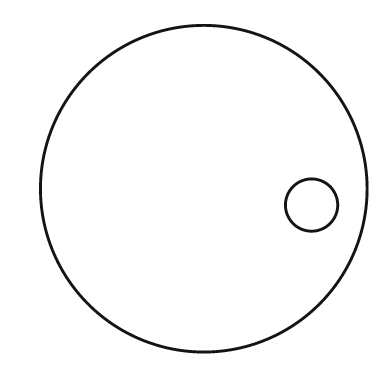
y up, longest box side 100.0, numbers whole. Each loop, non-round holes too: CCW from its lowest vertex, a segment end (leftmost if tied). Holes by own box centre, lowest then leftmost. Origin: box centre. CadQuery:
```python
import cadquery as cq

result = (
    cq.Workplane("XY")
    .moveTo(0.0, 0.0)
    .circle(50.0)
    .moveTo(33.0, -5.0)
    .circle(8.0)
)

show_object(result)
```